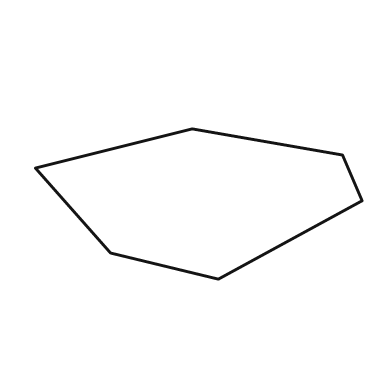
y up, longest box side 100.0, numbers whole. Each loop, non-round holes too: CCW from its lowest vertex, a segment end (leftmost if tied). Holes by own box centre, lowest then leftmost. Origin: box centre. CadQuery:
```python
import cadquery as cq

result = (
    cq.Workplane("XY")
    .moveTo(6.0, -23.0)
    .lineTo(50.0, 1.0)
    .lineTo(44.0, 15.0)
    .lineTo(-2.0, 23.0)
    .lineTo(-50.0, 11.0)
    .lineTo(-27.0, -15.0)
    .close()
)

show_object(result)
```